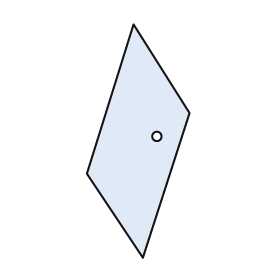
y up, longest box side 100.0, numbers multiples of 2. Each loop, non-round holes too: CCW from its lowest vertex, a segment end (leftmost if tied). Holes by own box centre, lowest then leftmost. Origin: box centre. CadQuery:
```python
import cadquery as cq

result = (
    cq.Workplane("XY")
    .moveTo(2.0, -50.0)
    .lineTo(22.0, 12.0)
    .lineTo(-2.0, 50.0)
    .lineTo(-22.0, -14.0)
    .close()
    .moveTo(8.0, 2.0)
    .circle(2.0)
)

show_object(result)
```